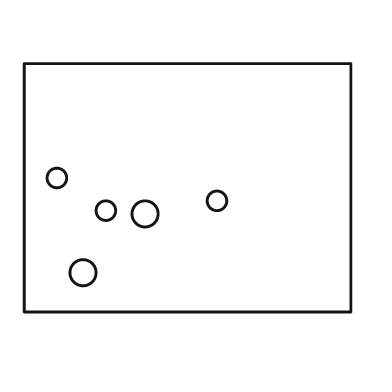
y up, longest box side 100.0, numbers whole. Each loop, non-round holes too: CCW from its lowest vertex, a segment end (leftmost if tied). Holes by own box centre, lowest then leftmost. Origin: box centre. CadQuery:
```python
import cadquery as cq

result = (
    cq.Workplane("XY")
    .moveTo(-50.0, -38.0)
    .lineTo(50.0, -38.0)
    .lineTo(50.0, 38.0)
    .lineTo(-50.0, 38.0)
    .close()
    .moveTo(-32.0, -26.0)
    .circle(4.0)
    .moveTo(-13.0, -8.0)
    .circle(4.0)
    .moveTo(-25.0, -7.0)
    .circle(3.0)
    .moveTo(9.0, -4.0)
    .circle(3.0)
    .moveTo(-40.0, 3.0)
    .circle(3.0)
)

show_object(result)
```